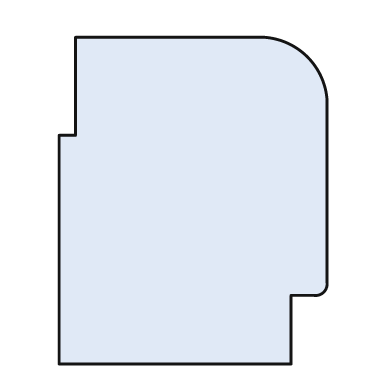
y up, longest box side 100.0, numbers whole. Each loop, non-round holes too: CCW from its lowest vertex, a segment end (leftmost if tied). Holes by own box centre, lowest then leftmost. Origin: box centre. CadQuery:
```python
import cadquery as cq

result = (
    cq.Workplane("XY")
    .moveTo(-41.0, -50.0)
    .lineTo(30.0, -50.0)
    .lineTo(30.0, -29.0)
    .lineTo(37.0, -29.0)
    .threePointArc((40.0, -28.0), (41.0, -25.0))
    .lineTo(41.0, 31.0)
    .threePointArc((35.0, 44.0), (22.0, 50.0))
    .lineTo(-36.0, 50.0)
    .lineTo(-36.0, 20.0)
    .lineTo(-41.0, 20.0)
    .close()
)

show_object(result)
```